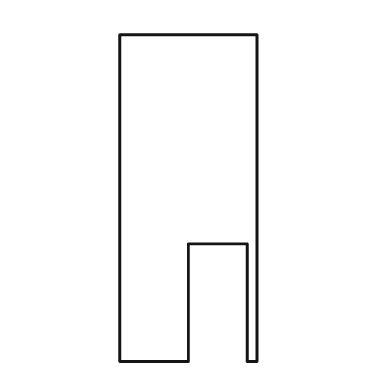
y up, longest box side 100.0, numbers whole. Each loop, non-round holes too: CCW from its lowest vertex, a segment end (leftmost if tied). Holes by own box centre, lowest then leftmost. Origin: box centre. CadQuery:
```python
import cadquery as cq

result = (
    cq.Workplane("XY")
    .moveTo(-21.0, -50.0)
    .lineTo(0.0, -50.0)
    .lineTo(0.0, -14.0)
    .lineTo(18.0, -14.0)
    .lineTo(18.0, -50.0)
    .lineTo(21.0, -50.0)
    .lineTo(21.0, 50.0)
    .lineTo(-21.0, 50.0)
    .close()
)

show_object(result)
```